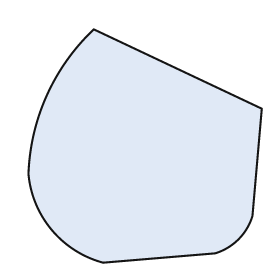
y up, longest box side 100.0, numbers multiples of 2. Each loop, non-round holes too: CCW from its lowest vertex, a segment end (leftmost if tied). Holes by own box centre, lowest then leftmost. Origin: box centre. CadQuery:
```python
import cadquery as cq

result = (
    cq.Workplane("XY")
    .moveTo(-18.0, -50.0)
    .lineTo(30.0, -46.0)
    .threePointArc((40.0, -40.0), (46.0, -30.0))
    .lineTo(50.0, 16.0)
    .lineTo(-22.0, 50.0)
    .threePointArc((-42.0, 22.0), (-50.0, -12.0))
    .threePointArc((-40.0, -36.0), (-18.0, -50.0))
    .close()
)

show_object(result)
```